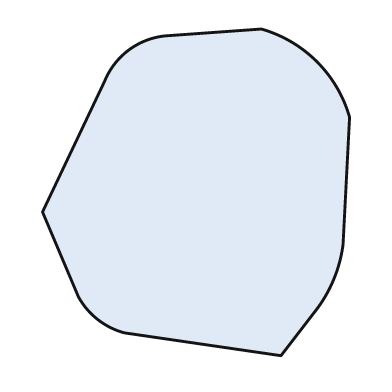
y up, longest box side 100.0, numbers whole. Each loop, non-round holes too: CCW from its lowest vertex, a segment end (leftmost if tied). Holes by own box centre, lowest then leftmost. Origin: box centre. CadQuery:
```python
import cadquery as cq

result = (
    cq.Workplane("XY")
    .moveTo(26.0, -50.0)
    .lineTo(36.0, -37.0)
    .threePointArc((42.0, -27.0), (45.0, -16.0))
    .lineTo(47.0, 23.0)
    .threePointArc((37.0, 40.0), (20.0, 50.0))
    .lineTo(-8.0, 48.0)
    .threePointArc((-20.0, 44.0), (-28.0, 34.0))
    .lineTo(-47.0, -6.0)
    .lineTo(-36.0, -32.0)
    .threePointArc((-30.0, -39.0), (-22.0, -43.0))
    .close()
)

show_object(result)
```